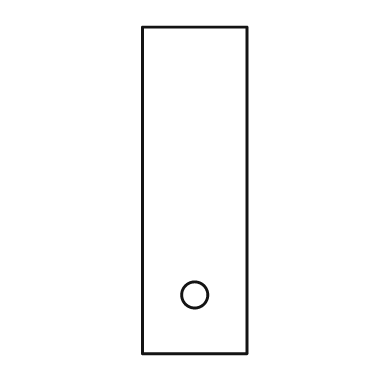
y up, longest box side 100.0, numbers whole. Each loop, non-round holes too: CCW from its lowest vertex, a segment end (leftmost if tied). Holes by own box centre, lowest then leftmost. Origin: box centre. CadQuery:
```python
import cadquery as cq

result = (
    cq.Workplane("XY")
    .moveTo(-16.0, -50.0)
    .lineTo(16.0, -50.0)
    .lineTo(16.0, 50.0)
    .lineTo(-16.0, 50.0)
    .close()
    .moveTo(0.0, -32.0)
    .circle(4.0)
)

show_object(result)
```